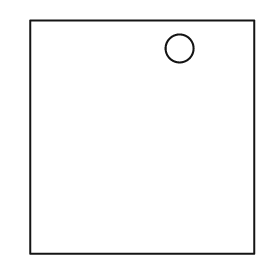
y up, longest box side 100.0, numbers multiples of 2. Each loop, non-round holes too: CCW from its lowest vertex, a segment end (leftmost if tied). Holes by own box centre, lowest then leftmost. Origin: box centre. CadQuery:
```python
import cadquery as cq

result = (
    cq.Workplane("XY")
    .moveTo(-48.0, -50.0)
    .lineTo(48.0, -50.0)
    .lineTo(48.0, 50.0)
    .lineTo(-48.0, 50.0)
    .close()
    .moveTo(16.0, 38.0)
    .circle(6.0)
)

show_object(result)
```